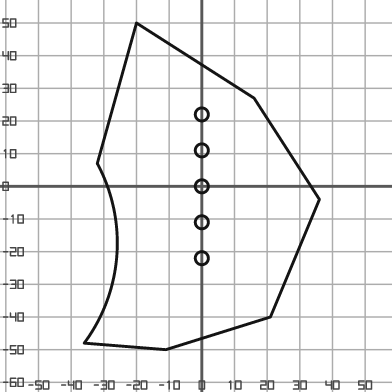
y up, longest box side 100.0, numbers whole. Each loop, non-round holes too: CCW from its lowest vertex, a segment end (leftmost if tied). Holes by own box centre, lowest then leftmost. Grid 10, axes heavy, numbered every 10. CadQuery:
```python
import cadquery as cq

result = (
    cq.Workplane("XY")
    .moveTo(-11.0, -50.0)
    .lineTo(21.0, -40.0)
    .lineTo(36.0, -4.0)
    .lineTo(16.0, 27.0)
    .lineTo(-20.0, 50.0)
    .lineTo(-32.0, 7.0)
    .threePointArc((-26.0, -21.0), (-36.0, -48.0))
    .close()
    .moveTo(0.0, -22.0)
    .circle(2.0)
    .moveTo(0.0, -11.0)
    .circle(2.0)
    .moveTo(0.0, 0.0)
    .circle(2.0)
    .moveTo(0.0, 11.0)
    .circle(2.0)
    .moveTo(0.0, 22.0)
    .circle(2.0)
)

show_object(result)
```